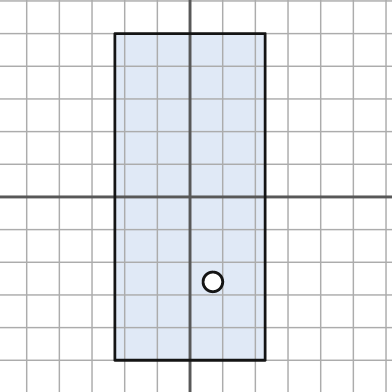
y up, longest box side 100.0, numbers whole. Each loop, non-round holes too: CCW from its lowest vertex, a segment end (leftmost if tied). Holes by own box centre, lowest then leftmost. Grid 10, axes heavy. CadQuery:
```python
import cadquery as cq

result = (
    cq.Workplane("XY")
    .moveTo(-23.0, -50.0)
    .lineTo(23.0, -50.0)
    .lineTo(23.0, 50.0)
    .lineTo(-23.0, 50.0)
    .close()
    .moveTo(7.0, -26.0)
    .circle(3.0)
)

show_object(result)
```